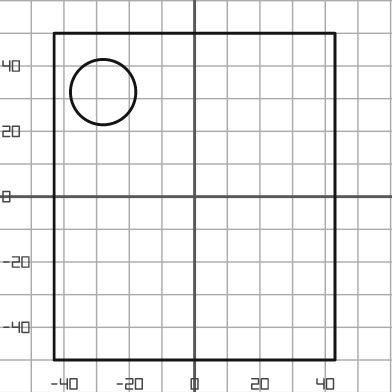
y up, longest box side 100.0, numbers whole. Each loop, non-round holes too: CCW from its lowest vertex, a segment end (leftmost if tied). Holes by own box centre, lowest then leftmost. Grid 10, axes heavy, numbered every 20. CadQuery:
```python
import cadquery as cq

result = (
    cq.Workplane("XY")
    .moveTo(-43.0, -50.0)
    .lineTo(43.0, -50.0)
    .lineTo(43.0, 50.0)
    .lineTo(-43.0, 50.0)
    .close()
    .moveTo(-28.0, 32.0)
    .circle(10.0)
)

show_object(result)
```